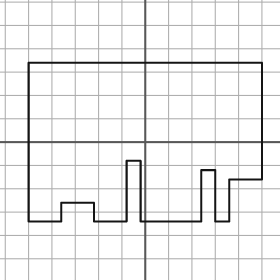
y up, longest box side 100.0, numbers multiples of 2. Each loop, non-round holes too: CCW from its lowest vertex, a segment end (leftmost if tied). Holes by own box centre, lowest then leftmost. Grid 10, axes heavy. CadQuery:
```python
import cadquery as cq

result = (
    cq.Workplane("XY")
    .moveTo(-50.0, -34.0)
    .lineTo(-36.0, -34.0)
    .lineTo(-36.0, -26.0)
    .lineTo(-22.0, -26.0)
    .lineTo(-22.0, -34.0)
    .lineTo(-8.0, -34.0)
    .lineTo(-8.0, -8.0)
    .lineTo(-2.0, -8.0)
    .lineTo(-2.0, -34.0)
    .lineTo(24.0, -34.0)
    .lineTo(24.0, -12.0)
    .lineTo(30.0, -12.0)
    .lineTo(30.0, -34.0)
    .lineTo(36.0, -34.0)
    .lineTo(36.0, -16.0)
    .lineTo(50.0, -16.0)
    .lineTo(50.0, 34.0)
    .lineTo(-50.0, 34.0)
    .close()
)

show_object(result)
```